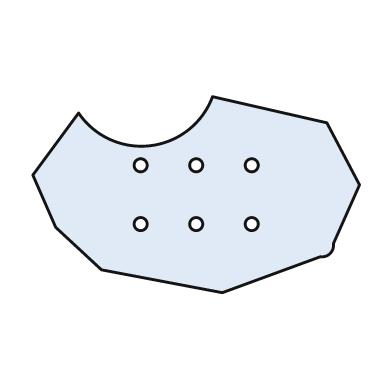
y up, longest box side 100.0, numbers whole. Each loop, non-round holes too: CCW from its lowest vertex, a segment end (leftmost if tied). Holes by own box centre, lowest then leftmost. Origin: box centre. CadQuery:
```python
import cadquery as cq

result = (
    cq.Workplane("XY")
    .moveTo(8.0, -30.0)
    .lineTo(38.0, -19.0)
    .threePointArc((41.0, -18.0), (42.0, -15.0))
    .lineTo(50.0, 3.0)
    .lineTo(40.0, 22.0)
    .lineTo(5.0, 30.0)
    .threePointArc((-14.0, 15.0), (-36.0, 25.0))
    .lineTo(-50.0, 6.0)
    .lineTo(-43.0, -10.0)
    .lineTo(-29.0, -23.0)
    .close()
    .moveTo(-17.0, -9.0)
    .circle(2.0)
    .moveTo(0.0, -9.0)
    .circle(2.0)
    .moveTo(17.0, -9.0)
    .circle(2.0)
    .moveTo(-17.0, 9.0)
    .circle(2.0)
    .moveTo(0.0, 9.0)
    .circle(2.0)
    .moveTo(17.0, 9.0)
    .circle(2.0)
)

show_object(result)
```